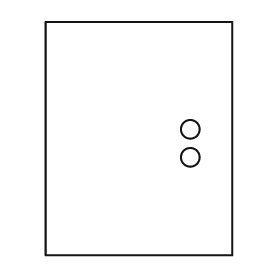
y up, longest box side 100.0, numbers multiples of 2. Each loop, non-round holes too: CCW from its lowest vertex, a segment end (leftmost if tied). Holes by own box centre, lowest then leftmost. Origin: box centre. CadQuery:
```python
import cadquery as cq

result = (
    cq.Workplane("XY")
    .moveTo(-40.0, -50.0)
    .lineTo(40.0, -50.0)
    .lineTo(40.0, 50.0)
    .lineTo(-40.0, 50.0)
    .close()
    .moveTo(22.0, -8.0)
    .circle(4.0)
    .moveTo(22.0, 4.0)
    .circle(4.0)
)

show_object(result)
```